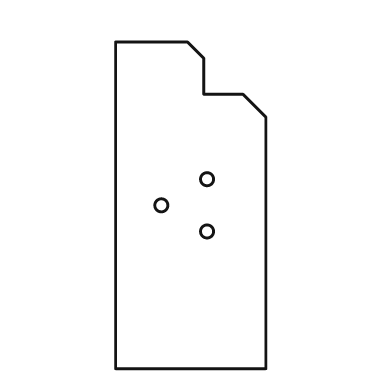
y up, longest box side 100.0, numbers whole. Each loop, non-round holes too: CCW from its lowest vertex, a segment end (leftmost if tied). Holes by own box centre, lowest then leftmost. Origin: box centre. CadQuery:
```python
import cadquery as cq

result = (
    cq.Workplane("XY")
    .moveTo(-23.0, -50.0)
    .lineTo(23.0, -50.0)
    .lineTo(23.0, 27.0)
    .lineTo(16.0, 34.0)
    .lineTo(4.0, 34.0)
    .lineTo(4.0, 45.0)
    .lineTo(-1.0, 50.0)
    .lineTo(-23.0, 50.0)
    .close()
    .moveTo(5.0, -8.0)
    .circle(2.0)
    .moveTo(-9.0, 0.0)
    .circle(2.0)
    .moveTo(5.0, 8.0)
    .circle(2.0)
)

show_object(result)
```